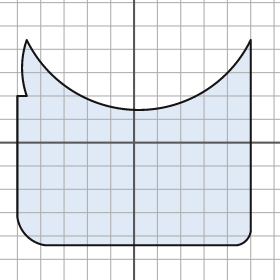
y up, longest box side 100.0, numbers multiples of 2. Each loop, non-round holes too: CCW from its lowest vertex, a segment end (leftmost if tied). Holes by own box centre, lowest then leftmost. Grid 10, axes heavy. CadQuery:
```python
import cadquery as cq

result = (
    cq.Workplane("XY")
    .moveTo(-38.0, -44.0)
    .lineTo(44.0, -44.0)
    .threePointArc((48.0, -42.0), (50.0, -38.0))
    .lineTo(50.0, 44.0)
    .threePointArc((2.0, 14.0), (-46.0, 44.0))
    .threePointArc((-48.0, 32.0), (-46.0, 20.0))
    .lineTo(-50.0, 20.0)
    .lineTo(-50.0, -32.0)
    .threePointArc((-46.0, -40.0), (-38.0, -44.0))
    .close()
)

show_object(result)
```